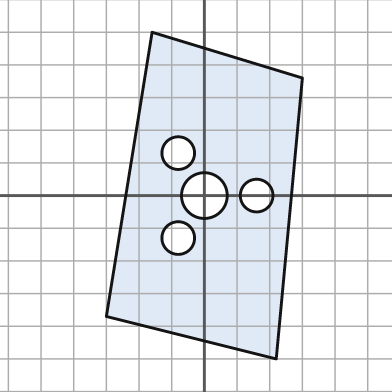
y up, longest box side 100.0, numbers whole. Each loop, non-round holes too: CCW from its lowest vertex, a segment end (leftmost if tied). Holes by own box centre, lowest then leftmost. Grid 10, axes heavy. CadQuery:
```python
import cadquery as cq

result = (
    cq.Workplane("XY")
    .moveTo(22.0, -50.0)
    .lineTo(30.0, 36.0)
    .lineTo(-16.0, 50.0)
    .lineTo(-30.0, -37.0)
    .close()
    .moveTo(-8.0, -13.0)
    .circle(5.0)
    .moveTo(0.0, 0.0)
    .circle(7.0)
    .moveTo(16.0, 0.0)
    .circle(5.0)
    .moveTo(-8.0, 13.0)
    .circle(5.0)
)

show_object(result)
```